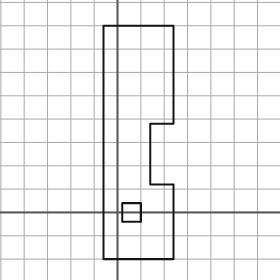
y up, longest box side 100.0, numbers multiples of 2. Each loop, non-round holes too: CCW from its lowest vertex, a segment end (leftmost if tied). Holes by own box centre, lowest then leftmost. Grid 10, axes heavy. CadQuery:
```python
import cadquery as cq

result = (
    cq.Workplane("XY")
    .moveTo(-6.0, -20.0)
    .lineTo(24.0, -20.0)
    .lineTo(24.0, 12.0)
    .lineTo(14.0, 12.0)
    .lineTo(14.0, 38.0)
    .lineTo(24.0, 38.0)
    .lineTo(24.0, 80.0)
    .lineTo(-6.0, 80.0)
    .close()
    .moveTo(2.0, -4.0)
    .lineTo(10.0, -4.0)
    .lineTo(10.0, 4.0)
    .lineTo(2.0, 4.0)
    .close()
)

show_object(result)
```